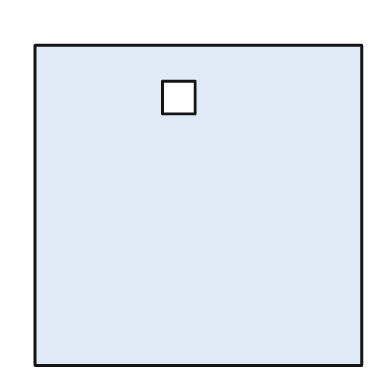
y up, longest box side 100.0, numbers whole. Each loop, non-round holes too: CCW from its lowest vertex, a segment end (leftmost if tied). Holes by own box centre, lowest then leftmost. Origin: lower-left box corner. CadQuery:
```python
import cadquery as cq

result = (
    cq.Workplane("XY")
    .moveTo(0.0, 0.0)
    .lineTo(100.0, 0.0)
    .lineTo(100.0, 98.0)
    .lineTo(0.0, 98.0)
    .close()
    .moveTo(39.0, 77.0)
    .lineTo(49.0, 77.0)
    .lineTo(49.0, 87.0)
    .lineTo(39.0, 87.0)
    .close()
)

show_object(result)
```